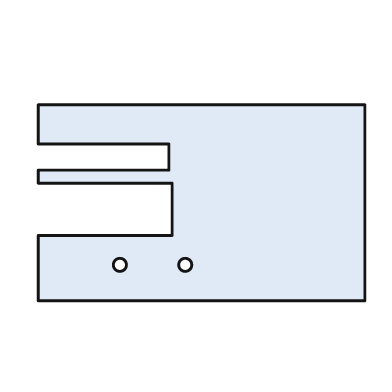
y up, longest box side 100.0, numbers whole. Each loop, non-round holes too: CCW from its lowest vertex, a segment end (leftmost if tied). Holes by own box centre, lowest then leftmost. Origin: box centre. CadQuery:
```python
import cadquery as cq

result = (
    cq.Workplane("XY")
    .moveTo(-50.0, -30.0)
    .lineTo(50.0, -30.0)
    .lineTo(50.0, 30.0)
    .lineTo(-50.0, 30.0)
    .lineTo(-50.0, 18.0)
    .lineTo(-10.0, 18.0)
    .lineTo(-10.0, 10.0)
    .lineTo(-50.0, 10.0)
    .lineTo(-50.0, 6.0)
    .lineTo(-9.0, 6.0)
    .lineTo(-9.0, -10.0)
    .lineTo(-50.0, -10.0)
    .close()
    .moveTo(-25.0, -19.0)
    .circle(2.0)
    .moveTo(-5.0, -19.0)
    .circle(2.0)
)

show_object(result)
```